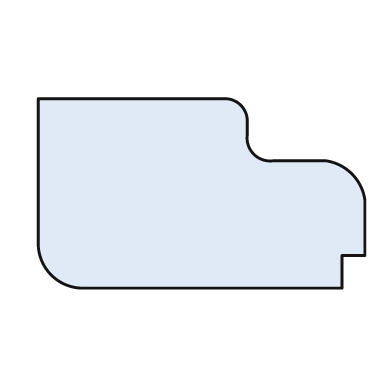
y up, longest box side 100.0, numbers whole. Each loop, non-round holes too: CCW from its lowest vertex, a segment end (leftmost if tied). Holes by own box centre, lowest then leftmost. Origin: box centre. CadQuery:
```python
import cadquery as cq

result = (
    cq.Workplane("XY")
    .moveTo(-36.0, -29.0)
    .lineTo(43.0, -29.0)
    .lineTo(43.0, -19.0)
    .lineTo(50.0, -19.0)
    .lineTo(50.0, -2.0)
    .threePointArc((46.0, 6.0), (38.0, 10.0))
    .lineTo(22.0, 10.0)
    .threePointArc((16.0, 12.0), (14.0, 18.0))
    .lineTo(14.0, 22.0)
    .threePointArc((12.0, 27.0), (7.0, 29.0))
    .lineTo(-50.0, 29.0)
    .lineTo(-50.0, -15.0)
    .threePointArc((-46.0, -25.0), (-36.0, -29.0))
    .close()
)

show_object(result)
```